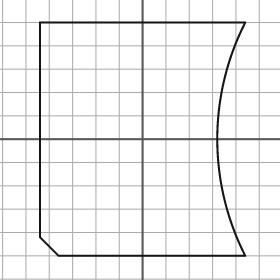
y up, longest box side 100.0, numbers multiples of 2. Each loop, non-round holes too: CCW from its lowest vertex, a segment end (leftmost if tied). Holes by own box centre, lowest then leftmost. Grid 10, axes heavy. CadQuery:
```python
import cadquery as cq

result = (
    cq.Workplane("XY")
    .moveTo(-36.0, -50.0)
    .lineTo(44.0, -50.0)
    .threePointArc((32.0, 0.0), (44.0, 50.0))
    .lineTo(-44.0, 50.0)
    .lineTo(-44.0, -42.0)
    .close()
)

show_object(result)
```